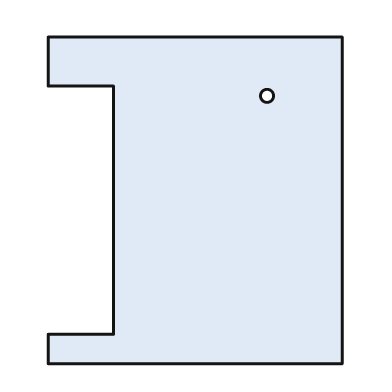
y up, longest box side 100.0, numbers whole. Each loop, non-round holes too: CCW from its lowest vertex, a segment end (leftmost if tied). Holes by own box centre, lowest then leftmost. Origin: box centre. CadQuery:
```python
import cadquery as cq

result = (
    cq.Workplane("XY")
    .moveTo(-45.0, -50.0)
    .lineTo(45.0, -50.0)
    .lineTo(45.0, 50.0)
    .lineTo(-45.0, 50.0)
    .lineTo(-45.0, 35.0)
    .lineTo(-25.0, 35.0)
    .lineTo(-25.0, -41.0)
    .lineTo(-45.0, -41.0)
    .close()
    .moveTo(22.0, 32.0)
    .circle(2.0)
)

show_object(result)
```